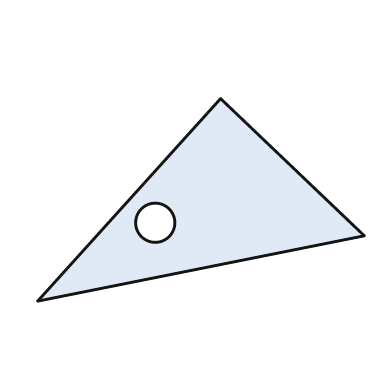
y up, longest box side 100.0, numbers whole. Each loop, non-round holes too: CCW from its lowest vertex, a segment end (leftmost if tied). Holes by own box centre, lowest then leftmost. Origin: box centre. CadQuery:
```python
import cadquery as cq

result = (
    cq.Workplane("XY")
    .moveTo(-50.0, -31.0)
    .lineTo(50.0, -11.0)
    .lineTo(6.0, 31.0)
    .close()
    .moveTo(-14.0, -7.0)
    .circle(6.0)
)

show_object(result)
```